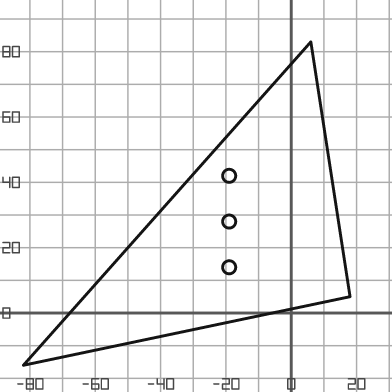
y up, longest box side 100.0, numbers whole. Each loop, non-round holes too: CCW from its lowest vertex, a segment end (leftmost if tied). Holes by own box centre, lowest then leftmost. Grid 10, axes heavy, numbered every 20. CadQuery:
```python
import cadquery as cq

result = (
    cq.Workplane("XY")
    .moveTo(-82.0, -16.0)
    .lineTo(18.0, 5.0)
    .lineTo(6.0, 83.0)
    .close()
    .moveTo(-19.0, 14.0)
    .circle(2.0)
    .moveTo(-19.0, 28.0)
    .circle(2.0)
    .moveTo(-19.0, 42.0)
    .circle(2.0)
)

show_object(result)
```